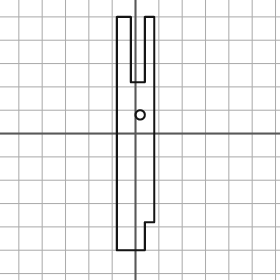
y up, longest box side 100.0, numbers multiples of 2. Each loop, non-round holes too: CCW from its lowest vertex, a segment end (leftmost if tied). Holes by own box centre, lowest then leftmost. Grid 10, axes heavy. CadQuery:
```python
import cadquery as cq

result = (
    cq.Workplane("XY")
    .moveTo(-8.0, -50.0)
    .lineTo(4.0, -50.0)
    .lineTo(4.0, -38.0)
    .lineTo(8.0, -38.0)
    .lineTo(8.0, 50.0)
    .lineTo(4.0, 50.0)
    .lineTo(4.0, 22.0)
    .lineTo(-2.0, 22.0)
    .lineTo(-2.0, 50.0)
    .lineTo(-8.0, 50.0)
    .close()
    .moveTo(2.0, 8.0)
    .circle(2.0)
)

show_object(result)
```